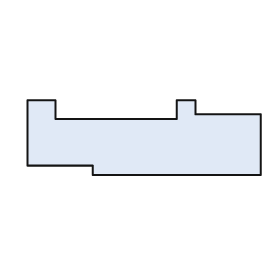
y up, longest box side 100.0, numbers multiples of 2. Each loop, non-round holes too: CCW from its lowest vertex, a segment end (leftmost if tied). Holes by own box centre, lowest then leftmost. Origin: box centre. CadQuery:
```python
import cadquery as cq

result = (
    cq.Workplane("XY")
    .moveTo(-22.0, -16.0)
    .lineTo(50.0, -16.0)
    .lineTo(50.0, 10.0)
    .lineTo(22.0, 10.0)
    .lineTo(22.0, 16.0)
    .lineTo(14.0, 16.0)
    .lineTo(14.0, 8.0)
    .lineTo(-38.0, 8.0)
    .lineTo(-38.0, 16.0)
    .lineTo(-50.0, 16.0)
    .lineTo(-50.0, -12.0)
    .lineTo(-22.0, -12.0)
    .close()
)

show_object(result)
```